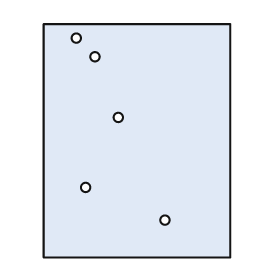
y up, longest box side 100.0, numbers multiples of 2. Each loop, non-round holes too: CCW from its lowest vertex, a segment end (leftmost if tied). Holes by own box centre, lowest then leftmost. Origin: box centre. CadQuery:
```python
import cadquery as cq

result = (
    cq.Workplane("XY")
    .moveTo(-40.0, -50.0)
    .lineTo(40.0, -50.0)
    .lineTo(40.0, 50.0)
    .lineTo(-40.0, 50.0)
    .close()
    .moveTo(12.0, -34.0)
    .circle(2.0)
    .moveTo(-22.0, -20.0)
    .circle(2.0)
    .moveTo(-8.0, 10.0)
    .circle(2.0)
    .moveTo(-18.0, 36.0)
    .circle(2.0)
    .moveTo(-26.0, 44.0)
    .circle(2.0)
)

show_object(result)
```